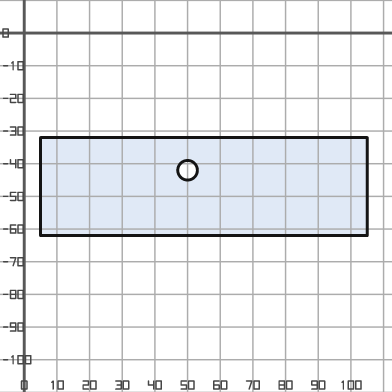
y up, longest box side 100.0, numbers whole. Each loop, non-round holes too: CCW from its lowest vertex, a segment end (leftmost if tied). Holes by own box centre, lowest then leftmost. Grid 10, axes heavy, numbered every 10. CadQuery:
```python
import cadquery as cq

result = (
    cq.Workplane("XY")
    .moveTo(5.0, -62.0)
    .lineTo(105.0, -62.0)
    .lineTo(105.0, -32.0)
    .lineTo(5.0, -32.0)
    .close()
    .moveTo(50.0, -42.0)
    .circle(3.0)
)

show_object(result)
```